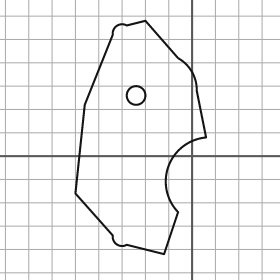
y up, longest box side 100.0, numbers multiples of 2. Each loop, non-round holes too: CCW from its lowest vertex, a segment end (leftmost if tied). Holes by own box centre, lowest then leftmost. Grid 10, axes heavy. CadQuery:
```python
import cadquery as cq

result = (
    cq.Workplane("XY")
    .moveTo(-12.0, -42.0)
    .lineTo(-6.0, -24.0)
    .threePointArc((-10.0, -4.0), (6.0, 8.0))
    .lineTo(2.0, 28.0)
    .threePointArc((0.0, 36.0), (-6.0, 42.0))
    .lineTo(-20.0, 58.0)
    .lineTo(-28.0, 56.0)
    .threePointArc((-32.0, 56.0), (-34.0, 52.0))
    .lineTo(-46.0, 22.0)
    .lineTo(-50.0, -16.0)
    .lineTo(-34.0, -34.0)
    .threePointArc((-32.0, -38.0), (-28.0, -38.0))
    .close()
    .moveTo(-24.0, 26.0)
    .circle(4.0)
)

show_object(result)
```